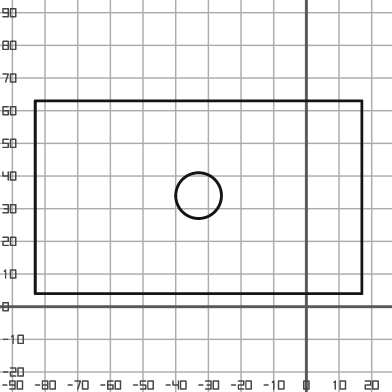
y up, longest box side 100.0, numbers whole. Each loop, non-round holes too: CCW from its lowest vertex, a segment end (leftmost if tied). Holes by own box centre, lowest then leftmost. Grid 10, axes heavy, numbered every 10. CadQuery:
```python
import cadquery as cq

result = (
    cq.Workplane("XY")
    .moveTo(-83.0, 4.0)
    .lineTo(17.0, 4.0)
    .lineTo(17.0, 63.0)
    .lineTo(-83.0, 63.0)
    .close()
    .moveTo(-33.0, 34.0)
    .circle(7.0)
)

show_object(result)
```